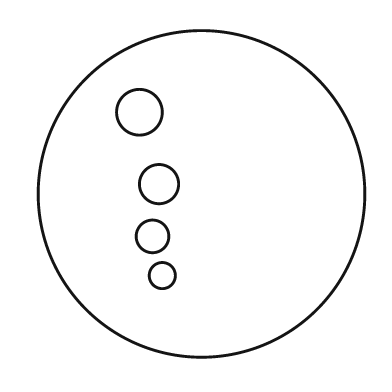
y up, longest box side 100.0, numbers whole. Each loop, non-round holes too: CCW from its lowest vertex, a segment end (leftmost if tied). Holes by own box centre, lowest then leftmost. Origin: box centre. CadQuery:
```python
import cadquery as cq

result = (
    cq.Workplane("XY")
    .moveTo(0.0, 0.0)
    .circle(50.0)
    .moveTo(-12.0, -25.0)
    .circle(4.0)
    .moveTo(-15.0, -13.0)
    .circle(5.0)
    .moveTo(-13.0, 3.0)
    .circle(6.0)
    .moveTo(-19.0, 25.0)
    .circle(7.0)
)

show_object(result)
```